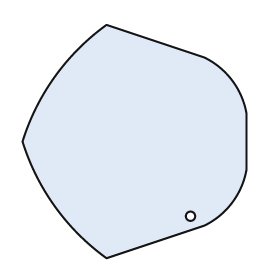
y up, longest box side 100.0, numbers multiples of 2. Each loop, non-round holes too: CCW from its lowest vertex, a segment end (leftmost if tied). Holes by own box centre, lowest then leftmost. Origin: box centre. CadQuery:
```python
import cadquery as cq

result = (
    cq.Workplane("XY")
    .moveTo(-12.0, -50.0)
    .lineTo(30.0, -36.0)
    .threePointArc((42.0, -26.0), (48.0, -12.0))
    .lineTo(48.0, 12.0)
    .threePointArc((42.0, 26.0), (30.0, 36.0))
    .lineTo(-12.0, 50.0)
    .threePointArc((-34.0, 28.0), (-48.0, 0.0))
    .threePointArc((-34.0, -28.0), (-12.0, -50.0))
    .close()
    .moveTo(24.0, -32.0)
    .circle(2.0)
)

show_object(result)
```